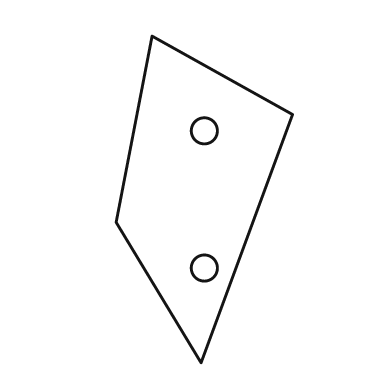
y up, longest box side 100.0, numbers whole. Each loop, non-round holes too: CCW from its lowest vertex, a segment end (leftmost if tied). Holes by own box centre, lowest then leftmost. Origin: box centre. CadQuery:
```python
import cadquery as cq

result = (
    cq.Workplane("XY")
    .moveTo(-1.0, -50.0)
    .lineTo(27.0, 26.0)
    .lineTo(-16.0, 50.0)
    .lineTo(-27.0, -7.0)
    .close()
    .moveTo(0.0, -21.0)
    .circle(4.0)
    .moveTo(0.0, 21.0)
    .circle(4.0)
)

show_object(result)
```